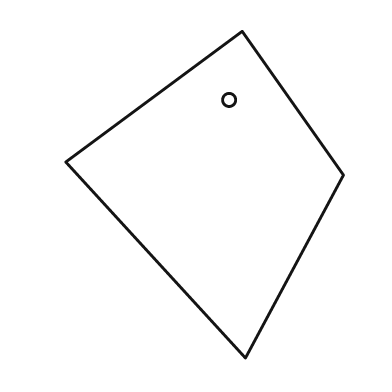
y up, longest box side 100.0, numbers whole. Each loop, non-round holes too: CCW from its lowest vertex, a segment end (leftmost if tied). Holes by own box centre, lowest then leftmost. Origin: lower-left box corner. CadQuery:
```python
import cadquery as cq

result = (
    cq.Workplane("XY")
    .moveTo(55.0, 0.0)
    .lineTo(85.0, 56.0)
    .lineTo(54.0, 100.0)
    .lineTo(0.0, 60.0)
    .close()
    .moveTo(50.0, 79.0)
    .circle(2.0)
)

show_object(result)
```